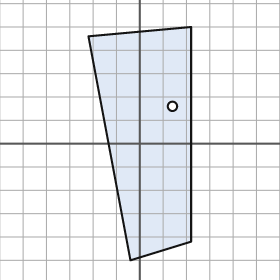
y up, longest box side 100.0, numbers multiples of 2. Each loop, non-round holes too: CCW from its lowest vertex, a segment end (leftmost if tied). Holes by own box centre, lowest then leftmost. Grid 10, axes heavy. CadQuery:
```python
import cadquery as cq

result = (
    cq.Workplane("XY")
    .moveTo(-4.0, -50.0)
    .lineTo(22.0, -42.0)
    .lineTo(22.0, 50.0)
    .lineTo(-22.0, 46.0)
    .close()
    .moveTo(14.0, 16.0)
    .circle(2.0)
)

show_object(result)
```